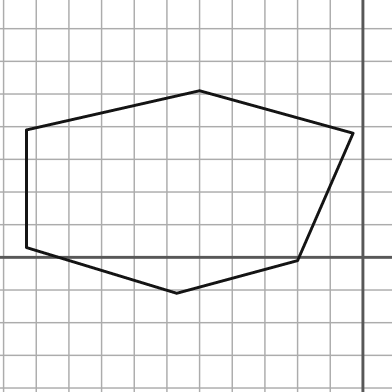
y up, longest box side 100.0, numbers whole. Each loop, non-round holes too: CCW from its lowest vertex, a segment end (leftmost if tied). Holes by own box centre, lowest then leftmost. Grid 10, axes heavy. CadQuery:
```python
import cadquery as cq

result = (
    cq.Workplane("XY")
    .moveTo(-57.0, -11.0)
    .lineTo(-20.0, -1.0)
    .lineTo(-3.0, 38.0)
    .lineTo(-50.0, 51.0)
    .lineTo(-103.0, 39.0)
    .lineTo(-103.0, 3.0)
    .close()
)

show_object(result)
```